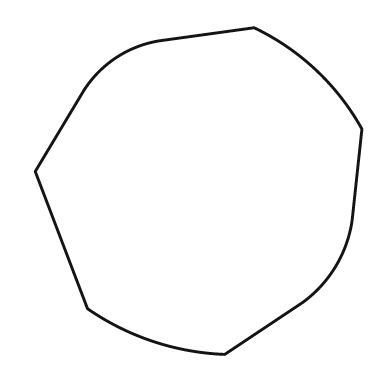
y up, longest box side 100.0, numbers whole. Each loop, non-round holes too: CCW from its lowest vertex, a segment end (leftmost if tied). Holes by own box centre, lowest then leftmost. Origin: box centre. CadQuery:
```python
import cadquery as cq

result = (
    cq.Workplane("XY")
    .moveTo(8.0, -50.0)
    .lineTo(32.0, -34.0)
    .threePointArc((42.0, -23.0), (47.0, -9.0))
    .lineTo(50.0, 19.0)
    .threePointArc((36.0, 37.0), (17.0, 50.0))
    .lineTo(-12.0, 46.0)
    .threePointArc((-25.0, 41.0), (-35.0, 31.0))
    .lineTo(-50.0, 6.0)
    .lineTo(-34.0, -36.0)
    .threePointArc((-14.0, -46.0), (8.0, -50.0))
    .close()
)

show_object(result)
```